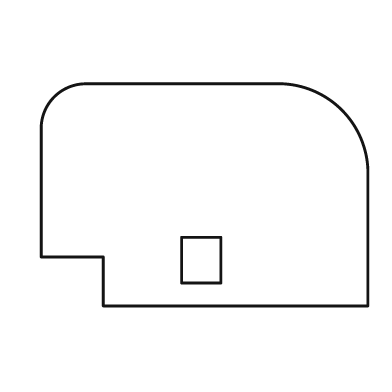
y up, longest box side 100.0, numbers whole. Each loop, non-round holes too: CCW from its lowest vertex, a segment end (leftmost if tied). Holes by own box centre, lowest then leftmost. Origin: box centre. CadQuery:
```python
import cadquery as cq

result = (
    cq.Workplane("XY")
    .moveTo(-31.0, -34.0)
    .lineTo(50.0, -34.0)
    .lineTo(50.0, 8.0)
    .threePointArc((42.0, 26.0), (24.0, 34.0))
    .lineTo(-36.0, 34.0)
    .threePointArc((-46.0, 30.0), (-50.0, 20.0))
    .lineTo(-50.0, -19.0)
    .lineTo(-31.0, -19.0)
    .close()
    .moveTo(-7.0, -27.0)
    .lineTo(5.0, -27.0)
    .lineTo(5.0, -13.0)
    .lineTo(-7.0, -13.0)
    .close()
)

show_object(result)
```